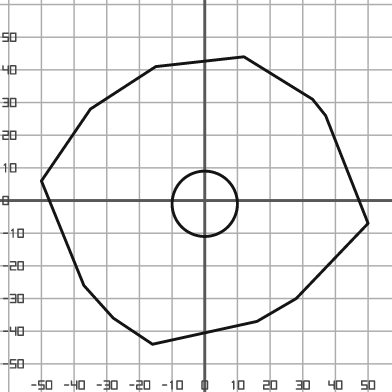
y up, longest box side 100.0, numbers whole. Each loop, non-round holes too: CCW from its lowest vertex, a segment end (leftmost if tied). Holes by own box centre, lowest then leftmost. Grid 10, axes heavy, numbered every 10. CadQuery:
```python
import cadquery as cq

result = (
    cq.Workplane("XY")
    .moveTo(-16.0, -44.0)
    .lineTo(16.0, -37.0)
    .lineTo(28.0, -30.0)
    .lineTo(50.0, -7.0)
    .lineTo(37.0, 26.0)
    .lineTo(33.0, 31.0)
    .lineTo(12.0, 44.0)
    .lineTo(-15.0, 41.0)
    .lineTo(-35.0, 28.0)
    .lineTo(-50.0, 6.0)
    .lineTo(-37.0, -26.0)
    .lineTo(-28.0, -36.0)
    .close()
    .moveTo(0.0, -1.0)
    .circle(10.0)
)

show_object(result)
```